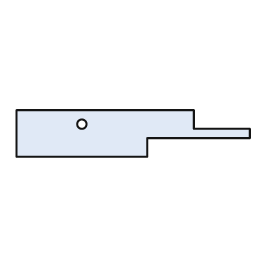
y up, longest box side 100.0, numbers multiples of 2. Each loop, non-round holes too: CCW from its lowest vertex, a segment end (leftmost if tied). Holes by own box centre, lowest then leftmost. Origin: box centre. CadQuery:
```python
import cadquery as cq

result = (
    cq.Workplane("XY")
    .moveTo(-50.0, -10.0)
    .lineTo(6.0, -10.0)
    .lineTo(6.0, -2.0)
    .lineTo(50.0, -2.0)
    .lineTo(50.0, 2.0)
    .lineTo(26.0, 2.0)
    .lineTo(26.0, 10.0)
    .lineTo(-50.0, 10.0)
    .close()
    .moveTo(-22.0, 4.0)
    .circle(2.0)
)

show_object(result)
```